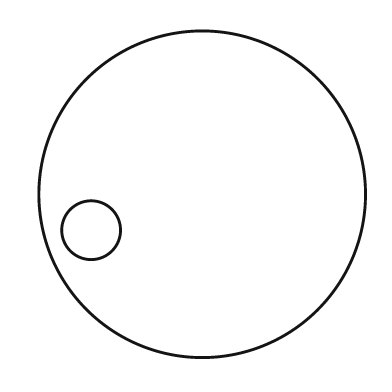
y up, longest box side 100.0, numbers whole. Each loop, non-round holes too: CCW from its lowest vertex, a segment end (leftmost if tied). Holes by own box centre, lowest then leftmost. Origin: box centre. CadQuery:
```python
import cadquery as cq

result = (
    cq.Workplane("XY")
    .moveTo(0.0, 0.0)
    .circle(50.0)
    .moveTo(-34.0, -11.0)
    .circle(9.0)
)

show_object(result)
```